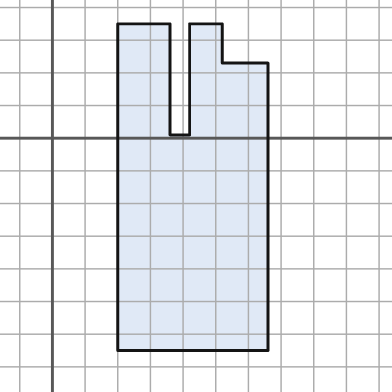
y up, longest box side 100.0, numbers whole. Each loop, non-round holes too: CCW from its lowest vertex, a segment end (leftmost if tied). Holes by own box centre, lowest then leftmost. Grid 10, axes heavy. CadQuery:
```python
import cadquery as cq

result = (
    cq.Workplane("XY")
    .moveTo(20.0, -65.0)
    .lineTo(66.0, -65.0)
    .lineTo(66.0, 23.0)
    .lineTo(52.0, 23.0)
    .lineTo(52.0, 35.0)
    .lineTo(42.0, 35.0)
    .lineTo(42.0, 1.0)
    .lineTo(36.0, 1.0)
    .lineTo(36.0, 35.0)
    .lineTo(20.0, 35.0)
    .close()
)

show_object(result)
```